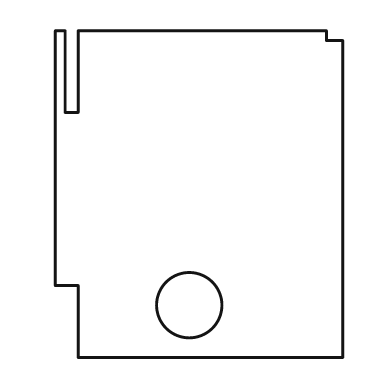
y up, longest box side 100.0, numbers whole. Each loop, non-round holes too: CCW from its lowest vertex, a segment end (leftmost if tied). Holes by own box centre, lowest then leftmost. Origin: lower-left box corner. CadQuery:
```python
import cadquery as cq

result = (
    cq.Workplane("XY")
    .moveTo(7.0, 0.0)
    .lineTo(88.0, 0.0)
    .lineTo(88.0, 97.0)
    .lineTo(83.0, 97.0)
    .lineTo(83.0, 100.0)
    .lineTo(7.0, 100.0)
    .lineTo(7.0, 75.0)
    .lineTo(3.0, 75.0)
    .lineTo(3.0, 100.0)
    .lineTo(0.0, 100.0)
    .lineTo(0.0, 22.0)
    .lineTo(7.0, 22.0)
    .close()
    .moveTo(41.0, 16.0)
    .circle(10.0)
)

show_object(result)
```